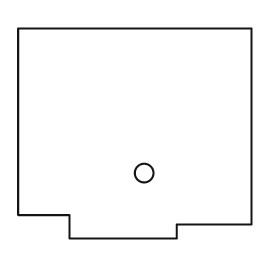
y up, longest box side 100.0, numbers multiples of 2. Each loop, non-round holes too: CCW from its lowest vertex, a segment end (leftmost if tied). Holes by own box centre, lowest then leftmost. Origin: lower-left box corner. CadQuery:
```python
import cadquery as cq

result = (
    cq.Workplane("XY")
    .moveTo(22.0, 0.0)
    .lineTo(68.0, 0.0)
    .lineTo(68.0, 6.0)
    .lineTo(100.0, 6.0)
    .lineTo(100.0, 90.0)
    .lineTo(0.0, 90.0)
    .lineTo(0.0, 10.0)
    .lineTo(22.0, 10.0)
    .close()
    .moveTo(54.0, 28.0)
    .circle(4.0)
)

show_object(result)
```